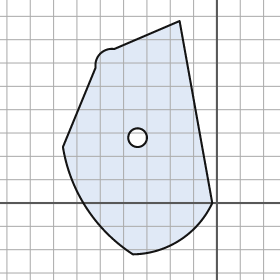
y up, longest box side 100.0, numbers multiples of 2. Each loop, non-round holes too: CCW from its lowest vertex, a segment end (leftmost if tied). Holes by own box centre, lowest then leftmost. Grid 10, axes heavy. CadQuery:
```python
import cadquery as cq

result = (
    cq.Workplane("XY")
    .moveTo(-36.0, -22.0)
    .threePointArc((-16.0, -16.0), (-2.0, 0.0))
    .lineTo(-16.0, 78.0)
    .lineTo(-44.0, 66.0)
    .threePointArc((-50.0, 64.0), (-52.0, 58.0))
    .lineTo(-66.0, 24.0)
    .threePointArc((-56.0, -2.0), (-36.0, -22.0))
    .close()
    .moveTo(-34.0, 28.0)
    .circle(4.0)
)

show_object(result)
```